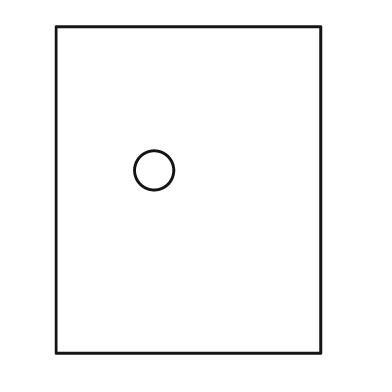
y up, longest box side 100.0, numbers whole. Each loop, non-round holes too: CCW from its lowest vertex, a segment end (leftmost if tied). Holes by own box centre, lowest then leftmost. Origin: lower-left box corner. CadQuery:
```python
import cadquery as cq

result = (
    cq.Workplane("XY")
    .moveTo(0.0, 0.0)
    .lineTo(81.0, 0.0)
    .lineTo(81.0, 100.0)
    .lineTo(0.0, 100.0)
    .close()
    .moveTo(30.0, 56.0)
    .circle(6.0)
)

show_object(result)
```